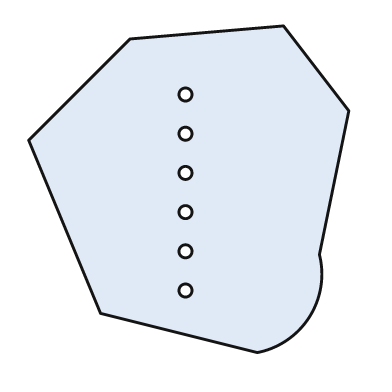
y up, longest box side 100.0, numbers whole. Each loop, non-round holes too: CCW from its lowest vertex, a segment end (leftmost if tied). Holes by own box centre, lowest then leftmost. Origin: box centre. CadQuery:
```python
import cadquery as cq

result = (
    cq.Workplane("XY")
    .moveTo(21.0, -50.0)
    .threePointArc((37.0, -39.0), (40.0, -20.0))
    .lineTo(49.0, 24.0)
    .lineTo(29.0, 50.0)
    .lineTo(-18.0, 46.0)
    .lineTo(-49.0, 15.0)
    .lineTo(-27.0, -38.0)
    .close()
    .moveTo(-1.0, -31.0)
    .circle(2.0)
    .moveTo(-1.0, -19.0)
    .circle(2.0)
    .moveTo(-1.0, -7.0)
    .circle(2.0)
    .moveTo(-1.0, 5.0)
    .circle(2.0)
    .moveTo(-1.0, 17.0)
    .circle(2.0)
    .moveTo(-1.0, 29.0)
    .circle(2.0)
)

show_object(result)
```